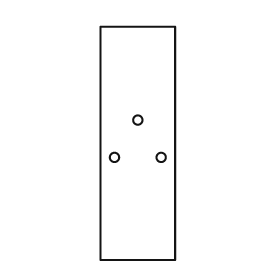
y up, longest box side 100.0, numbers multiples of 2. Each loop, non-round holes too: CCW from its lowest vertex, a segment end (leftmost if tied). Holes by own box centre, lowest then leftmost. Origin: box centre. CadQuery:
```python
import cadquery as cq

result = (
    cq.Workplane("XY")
    .moveTo(-16.0, -50.0)
    .lineTo(16.0, -50.0)
    .lineTo(16.0, 50.0)
    .lineTo(-16.0, 50.0)
    .close()
    .moveTo(-10.0, -6.0)
    .circle(2.0)
    .moveTo(10.0, -6.0)
    .circle(2.0)
    .moveTo(0.0, 10.0)
    .circle(2.0)
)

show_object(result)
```